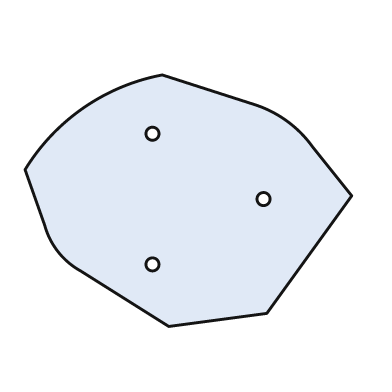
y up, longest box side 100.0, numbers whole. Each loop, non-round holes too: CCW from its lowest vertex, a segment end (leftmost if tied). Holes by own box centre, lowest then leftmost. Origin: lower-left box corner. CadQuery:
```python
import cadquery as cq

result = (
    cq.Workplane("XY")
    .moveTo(44.0, 0.0)
    .lineTo(74.0, 4.0)
    .lineTo(100.0, 40.0)
    .lineTo(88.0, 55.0)
    .threePointArc((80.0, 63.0), (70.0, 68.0))
    .lineTo(42.0, 77.0)
    .threePointArc((18.0, 67.0), (0.0, 48.0))
    .lineTo(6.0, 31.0)
    .threePointArc((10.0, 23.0), (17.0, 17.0))
    .close()
    .moveTo(39.0, 19.0)
    .circle(2.0)
    .moveTo(73.0, 39.0)
    .circle(2.0)
    .moveTo(39.0, 59.0)
    .circle(2.0)
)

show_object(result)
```